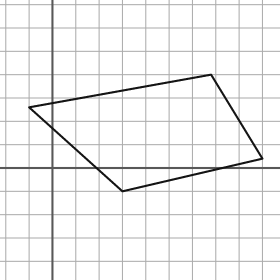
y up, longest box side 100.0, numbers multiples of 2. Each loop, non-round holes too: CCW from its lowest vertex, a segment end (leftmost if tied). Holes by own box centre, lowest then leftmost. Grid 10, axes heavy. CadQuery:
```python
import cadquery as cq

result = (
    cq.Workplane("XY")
    .moveTo(30.0, -10.0)
    .lineTo(90.0, 4.0)
    .lineTo(68.0, 40.0)
    .lineTo(-10.0, 26.0)
    .close()
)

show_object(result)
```